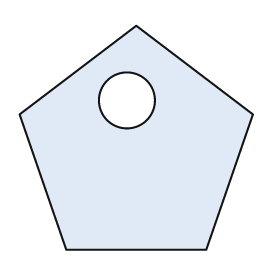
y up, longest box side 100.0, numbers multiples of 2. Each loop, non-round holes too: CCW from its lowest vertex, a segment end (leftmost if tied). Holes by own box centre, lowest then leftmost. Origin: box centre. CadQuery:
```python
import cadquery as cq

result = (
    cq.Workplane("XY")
    .moveTo(-30.0, -48.0)
    .lineTo(30.0, -48.0)
    .lineTo(50.0, 10.0)
    .lineTo(0.0, 48.0)
    .lineTo(-50.0, 10.0)
    .close()
    .moveTo(-4.0, 16.0)
    .circle(12.0)
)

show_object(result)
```